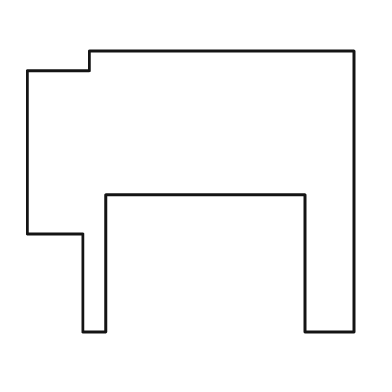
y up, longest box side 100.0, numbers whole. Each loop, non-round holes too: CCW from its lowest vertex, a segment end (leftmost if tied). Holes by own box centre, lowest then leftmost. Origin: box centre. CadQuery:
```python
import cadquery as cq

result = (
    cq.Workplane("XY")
    .moveTo(-33.0, -43.0)
    .lineTo(-26.0, -43.0)
    .lineTo(-26.0, -1.0)
    .lineTo(35.0, -1.0)
    .lineTo(35.0, -43.0)
    .lineTo(50.0, -43.0)
    .lineTo(50.0, 43.0)
    .lineTo(-31.0, 43.0)
    .lineTo(-31.0, 37.0)
    .lineTo(-50.0, 37.0)
    .lineTo(-50.0, -13.0)
    .lineTo(-33.0, -13.0)
    .close()
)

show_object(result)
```